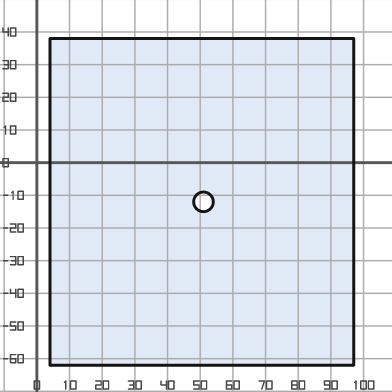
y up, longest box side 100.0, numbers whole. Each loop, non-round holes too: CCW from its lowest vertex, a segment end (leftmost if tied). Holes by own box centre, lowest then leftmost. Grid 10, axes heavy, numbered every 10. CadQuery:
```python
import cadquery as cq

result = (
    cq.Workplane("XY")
    .moveTo(4.0, -62.0)
    .lineTo(97.0, -62.0)
    .lineTo(97.0, 38.0)
    .lineTo(4.0, 38.0)
    .close()
    .moveTo(51.0, -12.0)
    .circle(3.0)
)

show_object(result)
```